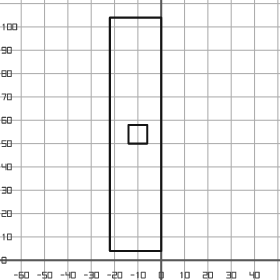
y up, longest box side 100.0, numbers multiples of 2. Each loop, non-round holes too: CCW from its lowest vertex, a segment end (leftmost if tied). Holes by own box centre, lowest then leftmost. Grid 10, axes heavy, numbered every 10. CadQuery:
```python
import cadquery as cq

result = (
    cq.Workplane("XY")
    .moveTo(-22.0, 4.0)
    .lineTo(0.0, 4.0)
    .lineTo(0.0, 104.0)
    .lineTo(-22.0, 104.0)
    .close()
    .moveTo(-14.0, 50.0)
    .lineTo(-6.0, 50.0)
    .lineTo(-6.0, 58.0)
    .lineTo(-14.0, 58.0)
    .close()
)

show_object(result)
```